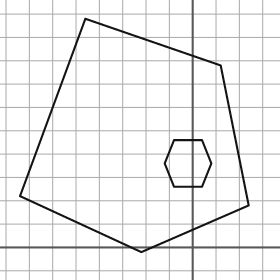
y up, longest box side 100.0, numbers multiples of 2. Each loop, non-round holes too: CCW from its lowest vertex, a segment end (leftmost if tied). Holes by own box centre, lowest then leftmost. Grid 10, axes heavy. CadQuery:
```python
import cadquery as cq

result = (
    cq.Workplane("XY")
    .moveTo(-22.0, -2.0)
    .lineTo(24.0, 18.0)
    .lineTo(12.0, 78.0)
    .lineTo(-46.0, 98.0)
    .lineTo(-74.0, 22.0)
    .close()
    .moveTo(-8.0, 26.0)
    .lineTo(4.0, 26.0)
    .lineTo(8.0, 36.0)
    .lineTo(4.0, 46.0)
    .lineTo(-8.0, 46.0)
    .lineTo(-12.0, 36.0)
    .close()
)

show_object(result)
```